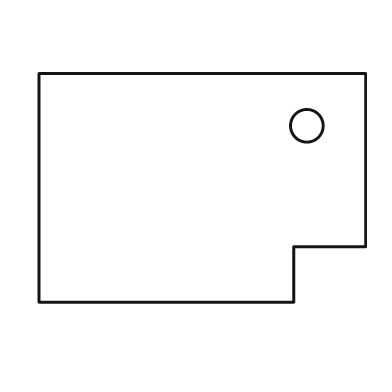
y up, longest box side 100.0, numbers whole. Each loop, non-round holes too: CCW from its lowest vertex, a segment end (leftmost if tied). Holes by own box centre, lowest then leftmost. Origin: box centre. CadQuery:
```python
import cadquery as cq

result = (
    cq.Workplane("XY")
    .moveTo(-50.0, -35.0)
    .lineTo(28.0, -35.0)
    .lineTo(28.0, -18.0)
    .lineTo(50.0, -18.0)
    .lineTo(50.0, 35.0)
    .lineTo(-50.0, 35.0)
    .close()
    .moveTo(32.0, 19.0)
    .circle(5.0)
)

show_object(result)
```